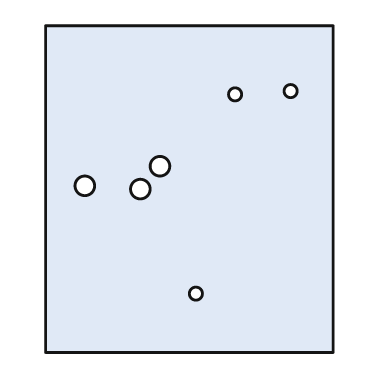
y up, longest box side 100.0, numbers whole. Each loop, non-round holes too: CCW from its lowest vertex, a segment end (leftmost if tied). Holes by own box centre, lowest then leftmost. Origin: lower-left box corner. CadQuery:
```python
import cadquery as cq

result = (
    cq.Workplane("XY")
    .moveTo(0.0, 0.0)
    .lineTo(88.0, 0.0)
    .lineTo(88.0, 100.0)
    .lineTo(0.0, 100.0)
    .close()
    .moveTo(46.0, 18.0)
    .circle(2.0)
    .moveTo(29.0, 50.0)
    .circle(3.0)
    .moveTo(12.0, 51.0)
    .circle(3.0)
    .moveTo(35.0, 57.0)
    .circle(3.0)
    .moveTo(58.0, 79.0)
    .circle(2.0)
    .moveTo(75.0, 80.0)
    .circle(2.0)
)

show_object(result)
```